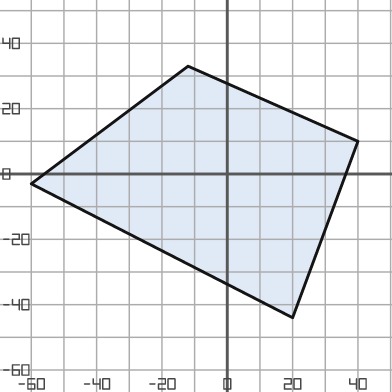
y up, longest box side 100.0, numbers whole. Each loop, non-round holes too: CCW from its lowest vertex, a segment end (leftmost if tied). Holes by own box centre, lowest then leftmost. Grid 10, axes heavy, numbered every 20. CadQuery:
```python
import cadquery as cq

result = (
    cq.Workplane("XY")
    .moveTo(20.0, -44.0)
    .lineTo(40.0, 10.0)
    .lineTo(-12.0, 33.0)
    .lineTo(-60.0, -3.0)
    .close()
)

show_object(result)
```